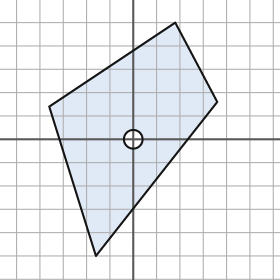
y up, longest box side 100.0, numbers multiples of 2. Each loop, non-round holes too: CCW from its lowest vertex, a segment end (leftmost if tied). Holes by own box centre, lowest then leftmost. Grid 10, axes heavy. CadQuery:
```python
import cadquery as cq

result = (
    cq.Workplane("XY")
    .moveTo(-16.0, -50.0)
    .lineTo(36.0, 16.0)
    .lineTo(18.0, 50.0)
    .lineTo(-36.0, 14.0)
    .close()
    .moveTo(0.0, 0.0)
    .circle(4.0)
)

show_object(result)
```